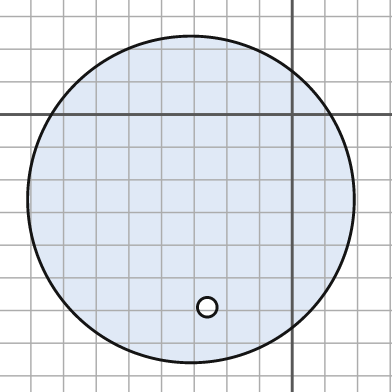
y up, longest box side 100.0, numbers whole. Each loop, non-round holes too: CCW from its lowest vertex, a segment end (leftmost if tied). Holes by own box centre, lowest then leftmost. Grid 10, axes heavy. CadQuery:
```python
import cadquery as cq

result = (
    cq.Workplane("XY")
    .moveTo(-31.0, -26.0)
    .circle(50.0)
    .moveTo(-26.0, -59.0)
    .circle(3.0)
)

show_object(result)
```